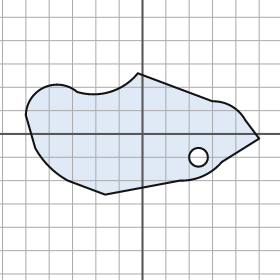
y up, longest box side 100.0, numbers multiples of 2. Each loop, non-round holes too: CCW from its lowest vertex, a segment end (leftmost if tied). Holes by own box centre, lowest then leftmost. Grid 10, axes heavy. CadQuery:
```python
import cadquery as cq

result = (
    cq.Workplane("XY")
    .moveTo(-16.0, -26.0)
    .lineTo(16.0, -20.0)
    .threePointArc((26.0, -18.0), (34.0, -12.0))
    .lineTo(50.0, -2.0)
    .lineTo(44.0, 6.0)
    .threePointArc((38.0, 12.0), (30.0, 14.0))
    .lineTo(-2.0, 26.0)
    .threePointArc((-14.0, 18.0), (-28.0, 18.0))
    .threePointArc((-42.0, 20.0), (-50.0, 8.0))
    .lineTo(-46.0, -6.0)
    .threePointArc((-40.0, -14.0), (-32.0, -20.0))
    .close()
    .moveTo(24.0, -10.0)
    .circle(4.0)
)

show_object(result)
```